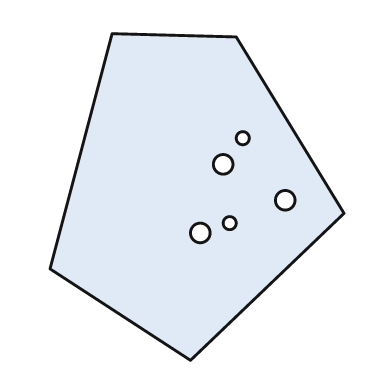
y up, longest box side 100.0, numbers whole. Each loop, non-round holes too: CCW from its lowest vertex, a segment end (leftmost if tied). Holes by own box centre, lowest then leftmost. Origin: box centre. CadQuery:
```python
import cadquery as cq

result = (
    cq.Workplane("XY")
    .moveTo(-2.0, -50.0)
    .lineTo(45.0, -5.0)
    .lineTo(12.0, 49.0)
    .lineTo(-26.0, 50.0)
    .lineTo(-45.0, -22.0)
    .close()
    .moveTo(1.0, -11.0)
    .circle(3.0)
    .moveTo(10.0, -8.0)
    .circle(2.0)
    .moveTo(27.0, -1.0)
    .circle(3.0)
    .moveTo(8.0, 10.0)
    .circle(3.0)
    .moveTo(14.0, 18.0)
    .circle(2.0)
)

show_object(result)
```